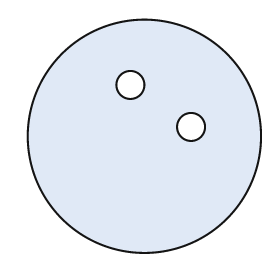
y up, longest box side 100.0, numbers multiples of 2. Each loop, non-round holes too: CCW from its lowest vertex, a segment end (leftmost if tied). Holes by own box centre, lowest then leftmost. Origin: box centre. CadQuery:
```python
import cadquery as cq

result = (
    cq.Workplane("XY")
    .moveTo(0.0, 0.0)
    .circle(50.0)
    .moveTo(20.0, 4.0)
    .circle(6.0)
    .moveTo(-6.0, 22.0)
    .circle(6.0)
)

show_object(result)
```